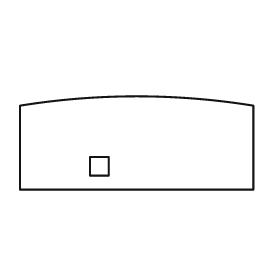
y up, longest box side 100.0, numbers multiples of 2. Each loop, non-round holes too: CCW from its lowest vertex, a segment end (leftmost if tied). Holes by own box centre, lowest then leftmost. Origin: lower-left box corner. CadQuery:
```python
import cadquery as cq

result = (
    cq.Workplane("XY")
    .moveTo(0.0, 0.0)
    .lineTo(100.0, 0.0)
    .lineTo(100.0, 36.0)
    .threePointArc((50.0, 40.0), (0.0, 36.0))
    .close()
    .moveTo(30.0, 6.0)
    .lineTo(38.0, 6.0)
    .lineTo(38.0, 14.0)
    .lineTo(30.0, 14.0)
    .close()
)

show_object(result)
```